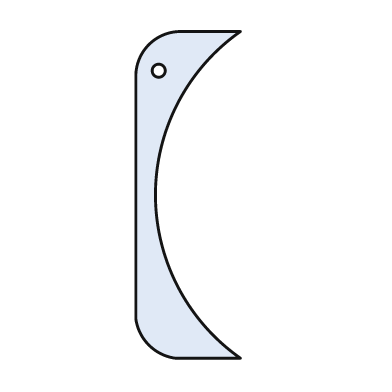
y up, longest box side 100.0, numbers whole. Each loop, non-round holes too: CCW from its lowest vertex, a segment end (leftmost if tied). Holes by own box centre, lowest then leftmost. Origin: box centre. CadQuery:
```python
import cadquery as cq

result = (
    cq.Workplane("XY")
    .moveTo(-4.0, -50.0)
    .lineTo(16.0, -50.0)
    .threePointArc((-10.0, 0.0), (16.0, 50.0))
    .lineTo(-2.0, 50.0)
    .threePointArc((-12.0, 46.0), (-16.0, 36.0))
    .lineTo(-16.0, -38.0)
    .threePointArc((-12.0, -46.0), (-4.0, -50.0))
    .close()
    .moveTo(-9.0, 38.0)
    .circle(2.0)
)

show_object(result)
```